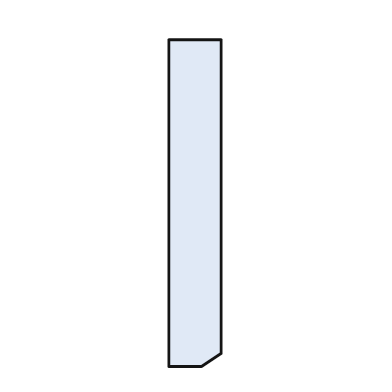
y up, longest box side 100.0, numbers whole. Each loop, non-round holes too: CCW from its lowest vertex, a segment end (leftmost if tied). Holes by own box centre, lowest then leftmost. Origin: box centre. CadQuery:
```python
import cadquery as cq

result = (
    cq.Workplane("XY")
    .moveTo(-8.0, -50.0)
    .lineTo(2.0, -50.0)
    .lineTo(8.0, -46.0)
    .lineTo(8.0, 50.0)
    .lineTo(-8.0, 50.0)
    .close()
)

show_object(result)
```